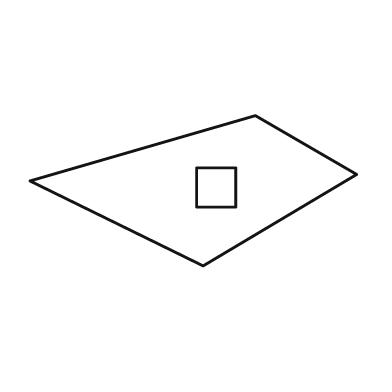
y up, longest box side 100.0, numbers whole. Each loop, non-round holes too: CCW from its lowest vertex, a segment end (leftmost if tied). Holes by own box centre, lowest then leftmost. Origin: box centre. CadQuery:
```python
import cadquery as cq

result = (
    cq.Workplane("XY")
    .moveTo(3.0, -23.0)
    .lineTo(50.0, 5.0)
    .lineTo(19.0, 23.0)
    .lineTo(-50.0, 3.0)
    .close()
    .moveTo(1.0, -5.0)
    .lineTo(13.0, -5.0)
    .lineTo(13.0, 7.0)
    .lineTo(1.0, 7.0)
    .close()
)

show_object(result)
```